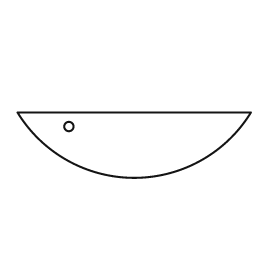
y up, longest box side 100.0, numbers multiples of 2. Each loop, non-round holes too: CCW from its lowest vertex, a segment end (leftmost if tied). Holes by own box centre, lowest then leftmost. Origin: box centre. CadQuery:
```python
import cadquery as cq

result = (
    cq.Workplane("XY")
    .moveTo(-50.0, 14.0)
    .threePointArc((0.0, -14.0), (50.0, 14.0))
    .close()
    .moveTo(-28.0, 8.0)
    .circle(2.0)
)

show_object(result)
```